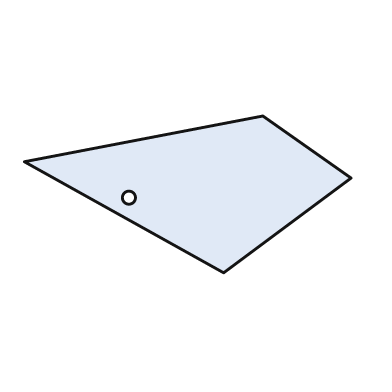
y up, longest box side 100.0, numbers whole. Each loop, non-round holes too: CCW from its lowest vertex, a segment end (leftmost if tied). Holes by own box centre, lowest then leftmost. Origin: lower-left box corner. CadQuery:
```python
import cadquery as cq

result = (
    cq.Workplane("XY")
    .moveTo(61.0, 0.0)
    .lineTo(100.0, 29.0)
    .lineTo(73.0, 48.0)
    .lineTo(0.0, 34.0)
    .close()
    .moveTo(32.0, 23.0)
    .circle(2.0)
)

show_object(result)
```